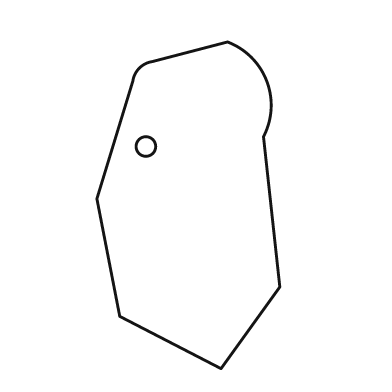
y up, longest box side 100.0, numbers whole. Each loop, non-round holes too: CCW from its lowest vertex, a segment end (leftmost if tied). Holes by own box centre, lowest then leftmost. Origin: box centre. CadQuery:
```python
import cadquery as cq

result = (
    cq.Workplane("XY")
    .moveTo(10.0, -50.0)
    .lineTo(28.0, -25.0)
    .lineTo(23.0, 21.0)
    .threePointArc((24.0, 38.0), (12.0, 50.0))
    .lineTo(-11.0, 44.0)
    .threePointArc((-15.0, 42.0), (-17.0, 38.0))
    .lineTo(-28.0, 2.0)
    .lineTo(-21.0, -34.0)
    .close()
    .moveTo(-13.0, 18.0)
    .circle(3.0)
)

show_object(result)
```